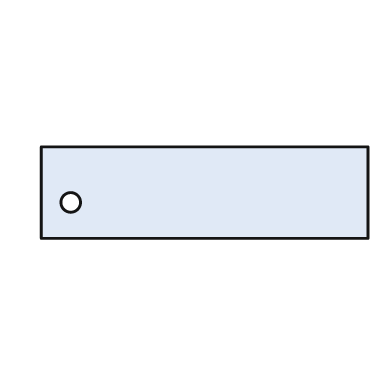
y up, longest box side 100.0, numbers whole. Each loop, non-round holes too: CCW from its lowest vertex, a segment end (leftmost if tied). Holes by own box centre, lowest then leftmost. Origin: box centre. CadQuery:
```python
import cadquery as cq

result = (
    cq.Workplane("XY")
    .moveTo(-50.0, -14.0)
    .lineTo(50.0, -14.0)
    .lineTo(50.0, 14.0)
    .lineTo(-50.0, 14.0)
    .close()
    .moveTo(-41.0, -3.0)
    .circle(3.0)
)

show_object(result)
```